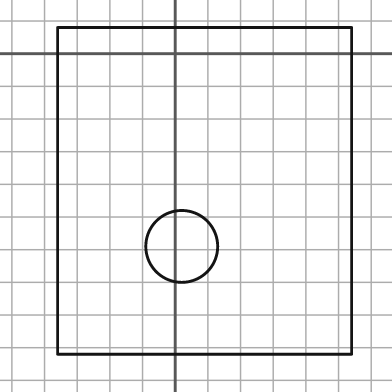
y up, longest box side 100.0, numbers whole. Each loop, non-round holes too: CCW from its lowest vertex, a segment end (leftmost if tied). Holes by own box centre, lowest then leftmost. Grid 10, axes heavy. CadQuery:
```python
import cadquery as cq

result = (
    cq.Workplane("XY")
    .moveTo(-36.0, -92.0)
    .lineTo(54.0, -92.0)
    .lineTo(54.0, 8.0)
    .lineTo(-36.0, 8.0)
    .close()
    .moveTo(2.0, -59.0)
    .circle(11.0)
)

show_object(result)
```